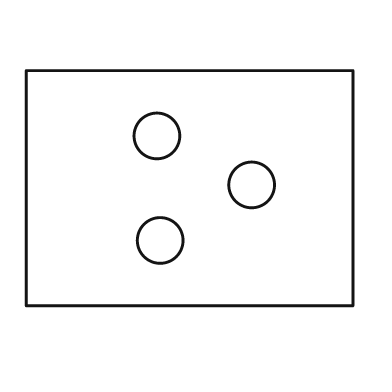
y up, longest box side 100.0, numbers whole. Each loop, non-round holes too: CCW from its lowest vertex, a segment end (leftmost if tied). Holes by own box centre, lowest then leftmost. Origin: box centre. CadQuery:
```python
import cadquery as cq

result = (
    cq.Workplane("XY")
    .moveTo(-50.0, -36.0)
    .lineTo(50.0, -36.0)
    .lineTo(50.0, 36.0)
    .lineTo(-50.0, 36.0)
    .close()
    .moveTo(-9.0, -16.0)
    .circle(7.0)
    .moveTo(19.0, 1.0)
    .circle(7.0)
    .moveTo(-10.0, 16.0)
    .circle(7.0)
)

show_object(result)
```